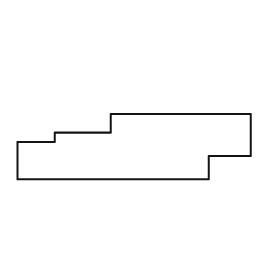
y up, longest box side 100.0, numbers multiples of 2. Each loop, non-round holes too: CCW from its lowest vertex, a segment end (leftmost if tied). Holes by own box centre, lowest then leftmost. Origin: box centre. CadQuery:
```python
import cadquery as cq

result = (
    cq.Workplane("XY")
    .moveTo(-50.0, -14.0)
    .lineTo(32.0, -14.0)
    .lineTo(32.0, -4.0)
    .lineTo(50.0, -4.0)
    .lineTo(50.0, 14.0)
    .lineTo(-10.0, 14.0)
    .lineTo(-10.0, 6.0)
    .lineTo(-34.0, 6.0)
    .lineTo(-34.0, 2.0)
    .lineTo(-50.0, 2.0)
    .close()
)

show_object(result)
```